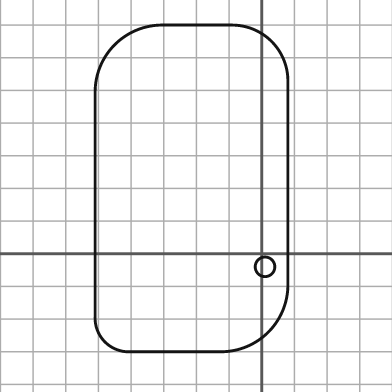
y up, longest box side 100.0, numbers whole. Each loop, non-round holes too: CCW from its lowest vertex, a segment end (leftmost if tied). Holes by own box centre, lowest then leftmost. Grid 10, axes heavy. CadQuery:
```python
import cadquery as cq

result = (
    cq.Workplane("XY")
    .moveTo(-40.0, -30.0)
    .lineTo(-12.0, -30.0)
    .threePointArc((2.0, -24.0), (8.0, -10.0))
    .lineTo(8.0, 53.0)
    .threePointArc((3.0, 65.0), (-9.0, 70.0))
    .lineTo(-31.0, 70.0)
    .threePointArc((-45.0, 64.0), (-51.0, 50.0))
    .lineTo(-51.0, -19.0)
    .threePointArc((-48.0, -27.0), (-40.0, -30.0))
    .close()
    .moveTo(1.0, -4.0)
    .circle(3.0)
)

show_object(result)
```